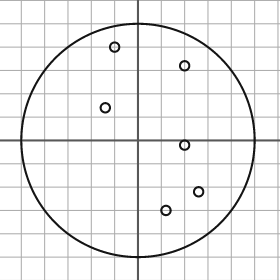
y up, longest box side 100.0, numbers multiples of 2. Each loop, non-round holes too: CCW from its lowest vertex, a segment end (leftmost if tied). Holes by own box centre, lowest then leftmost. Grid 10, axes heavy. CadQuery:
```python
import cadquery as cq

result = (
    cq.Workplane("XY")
    .moveTo(0.0, 0.0)
    .circle(50.0)
    .moveTo(12.0, -30.0)
    .circle(2.0)
    .moveTo(26.0, -22.0)
    .circle(2.0)
    .moveTo(20.0, -2.0)
    .circle(2.0)
    .moveTo(-14.0, 14.0)
    .circle(2.0)
    .moveTo(20.0, 32.0)
    .circle(2.0)
    .moveTo(-10.0, 40.0)
    .circle(2.0)
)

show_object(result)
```